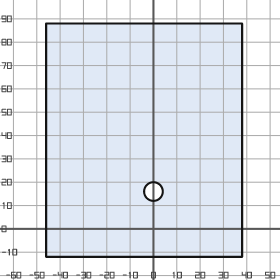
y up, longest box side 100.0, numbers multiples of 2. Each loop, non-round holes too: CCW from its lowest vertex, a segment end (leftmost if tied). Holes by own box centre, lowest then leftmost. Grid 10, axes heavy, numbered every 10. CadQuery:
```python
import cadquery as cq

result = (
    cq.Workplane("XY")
    .moveTo(-46.0, -12.0)
    .lineTo(38.0, -12.0)
    .lineTo(38.0, 88.0)
    .lineTo(-46.0, 88.0)
    .close()
    .moveTo(0.0, 16.0)
    .circle(4.0)
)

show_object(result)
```